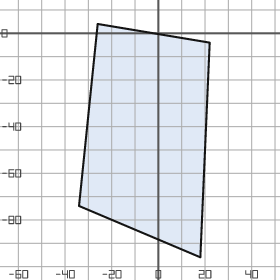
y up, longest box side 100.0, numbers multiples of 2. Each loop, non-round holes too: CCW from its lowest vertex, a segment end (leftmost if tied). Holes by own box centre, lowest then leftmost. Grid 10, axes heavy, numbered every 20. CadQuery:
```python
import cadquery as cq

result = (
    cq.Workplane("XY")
    .moveTo(18.0, -96.0)
    .lineTo(22.0, -4.0)
    .lineTo(-26.0, 4.0)
    .lineTo(-34.0, -74.0)
    .close()
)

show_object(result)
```